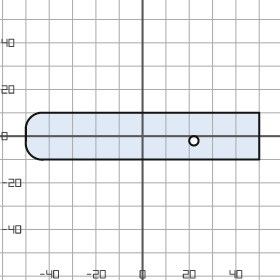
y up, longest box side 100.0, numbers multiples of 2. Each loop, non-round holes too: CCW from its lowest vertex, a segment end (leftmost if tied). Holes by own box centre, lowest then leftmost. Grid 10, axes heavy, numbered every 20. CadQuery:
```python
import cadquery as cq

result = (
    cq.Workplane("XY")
    .moveTo(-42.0, -10.0)
    .lineTo(50.0, -10.0)
    .lineTo(50.0, 10.0)
    .lineTo(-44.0, 10.0)
    .threePointArc((-48.0, 8.0), (-50.0, 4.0))
    .lineTo(-50.0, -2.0)
    .threePointArc((-48.0, -8.0), (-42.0, -10.0))
    .close()
    .moveTo(22.0, -2.0)
    .circle(2.0)
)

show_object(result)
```